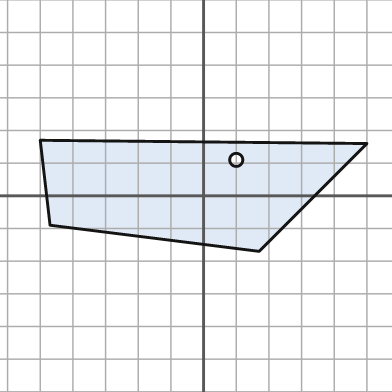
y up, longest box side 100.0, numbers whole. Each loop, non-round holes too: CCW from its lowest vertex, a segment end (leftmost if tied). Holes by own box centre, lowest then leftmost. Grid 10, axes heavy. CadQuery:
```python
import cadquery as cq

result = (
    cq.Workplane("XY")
    .moveTo(17.0, -17.0)
    .lineTo(50.0, 16.0)
    .lineTo(-50.0, 17.0)
    .lineTo(-47.0, -9.0)
    .close()
    .moveTo(10.0, 11.0)
    .circle(2.0)
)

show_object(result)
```